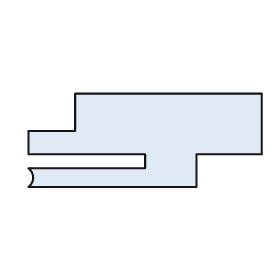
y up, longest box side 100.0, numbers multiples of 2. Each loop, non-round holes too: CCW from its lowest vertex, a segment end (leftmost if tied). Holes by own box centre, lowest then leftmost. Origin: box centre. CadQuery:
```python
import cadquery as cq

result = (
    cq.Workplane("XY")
    .moveTo(-50.0, -20.0)
    .lineTo(22.0, -20.0)
    .lineTo(22.0, -6.0)
    .lineTo(50.0, -6.0)
    .lineTo(50.0, 20.0)
    .lineTo(-30.0, 20.0)
    .lineTo(-30.0, 4.0)
    .lineTo(-50.0, 4.0)
    .lineTo(-50.0, -6.0)
    .lineTo(0.0, -6.0)
    .lineTo(0.0, -12.0)
    .lineTo(-50.0, -12.0)
    .threePointArc((-48.0, -16.0), (-50.0, -20.0))
    .close()
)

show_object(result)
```